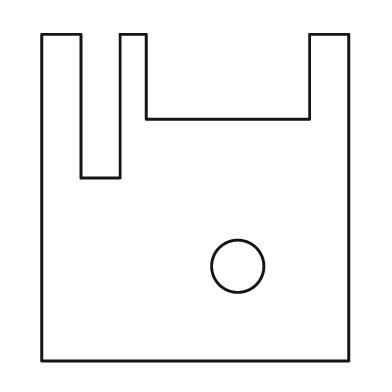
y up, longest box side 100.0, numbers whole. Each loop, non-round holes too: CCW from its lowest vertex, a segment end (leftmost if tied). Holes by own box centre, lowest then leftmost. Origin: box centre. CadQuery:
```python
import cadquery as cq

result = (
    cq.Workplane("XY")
    .moveTo(-47.0, -50.0)
    .lineTo(47.0, -50.0)
    .lineTo(47.0, 50.0)
    .lineTo(35.0, 50.0)
    .lineTo(35.0, 24.0)
    .lineTo(-15.0, 24.0)
    .lineTo(-15.0, 50.0)
    .lineTo(-23.0, 50.0)
    .lineTo(-23.0, 6.0)
    .lineTo(-35.0, 6.0)
    .lineTo(-35.0, 50.0)
    .lineTo(-47.0, 50.0)
    .close()
    .moveTo(13.0, -21.0)
    .circle(8.0)
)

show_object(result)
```